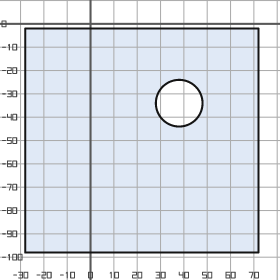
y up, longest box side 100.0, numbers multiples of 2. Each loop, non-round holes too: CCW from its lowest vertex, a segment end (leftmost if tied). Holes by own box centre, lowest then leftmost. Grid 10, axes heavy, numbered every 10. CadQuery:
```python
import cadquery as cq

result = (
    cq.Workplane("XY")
    .moveTo(-28.0, -98.0)
    .lineTo(72.0, -98.0)
    .lineTo(72.0, -2.0)
    .lineTo(-28.0, -2.0)
    .close()
    .moveTo(38.0, -34.0)
    .circle(10.0)
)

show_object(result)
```